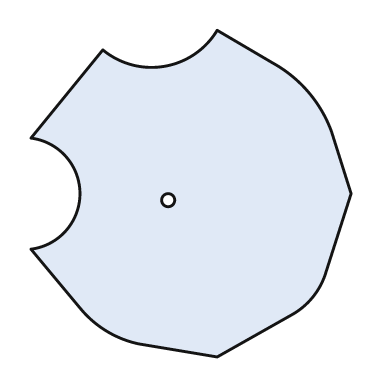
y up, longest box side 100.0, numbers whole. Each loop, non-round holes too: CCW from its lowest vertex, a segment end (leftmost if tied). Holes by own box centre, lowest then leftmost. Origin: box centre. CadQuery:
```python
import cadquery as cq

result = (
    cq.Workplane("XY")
    .moveTo(8.0, -50.0)
    .lineTo(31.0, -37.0)
    .threePointArc((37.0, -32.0), (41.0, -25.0))
    .lineTo(49.0, 0.0)
    .lineTo(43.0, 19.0)
    .threePointArc((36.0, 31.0), (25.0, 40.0))
    .lineTo(8.0, 50.0)
    .threePointArc((-8.0, 39.0), (-27.0, 44.0))
    .lineTo(-49.0, 17.0)
    .threePointArc((-34.0, 0.0), (-49.0, -17.0))
    .lineTo(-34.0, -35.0)
    .threePointArc((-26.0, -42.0), (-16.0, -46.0))
    .close()
    .moveTo(-7.0, -2.0)
    .circle(2.0)
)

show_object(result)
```